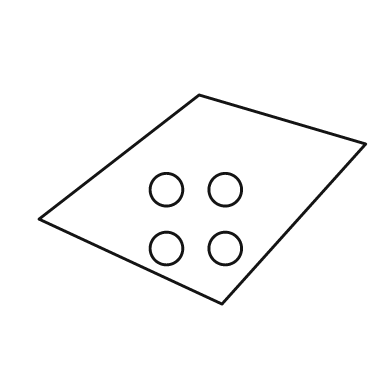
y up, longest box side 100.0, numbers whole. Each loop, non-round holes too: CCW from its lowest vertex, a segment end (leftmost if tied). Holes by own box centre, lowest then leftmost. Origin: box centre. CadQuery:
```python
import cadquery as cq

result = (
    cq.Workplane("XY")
    .moveTo(6.0, -32.0)
    .lineTo(50.0, 17.0)
    .lineTo(-1.0, 32.0)
    .lineTo(-50.0, -6.0)
    .close()
    .moveTo(-11.0, -15.0)
    .circle(5.0)
    .moveTo(7.0, -15.0)
    .circle(5.0)
    .moveTo(-11.0, 3.0)
    .circle(5.0)
    .moveTo(7.0, 3.0)
    .circle(5.0)
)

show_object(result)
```